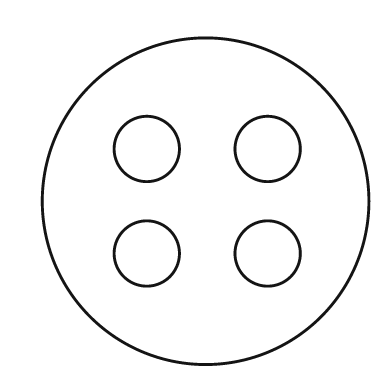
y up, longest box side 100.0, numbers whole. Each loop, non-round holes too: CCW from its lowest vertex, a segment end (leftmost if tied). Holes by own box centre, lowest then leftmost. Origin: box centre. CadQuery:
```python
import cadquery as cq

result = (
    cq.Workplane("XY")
    .moveTo(0.0, 0.0)
    .circle(50.0)
    .moveTo(-18.0, -16.0)
    .circle(10.0)
    .moveTo(19.0, -16.0)
    .circle(10.0)
    .moveTo(-18.0, 16.0)
    .circle(10.0)
    .moveTo(19.0, 16.0)
    .circle(10.0)
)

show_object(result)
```